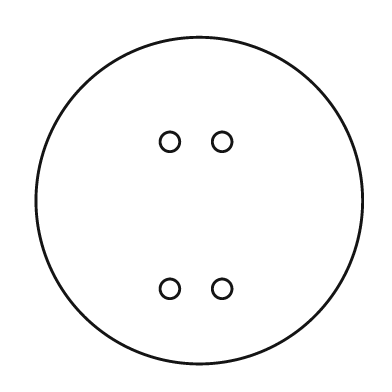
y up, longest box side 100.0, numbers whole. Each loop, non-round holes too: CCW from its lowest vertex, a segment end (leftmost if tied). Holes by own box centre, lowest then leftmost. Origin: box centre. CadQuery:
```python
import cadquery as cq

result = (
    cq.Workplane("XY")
    .moveTo(0.0, 0.0)
    .circle(50.0)
    .moveTo(-9.0, -27.0)
    .circle(3.0)
    .moveTo(7.0, -27.0)
    .circle(3.0)
    .moveTo(-9.0, 18.0)
    .circle(3.0)
    .moveTo(7.0, 18.0)
    .circle(3.0)
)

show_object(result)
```